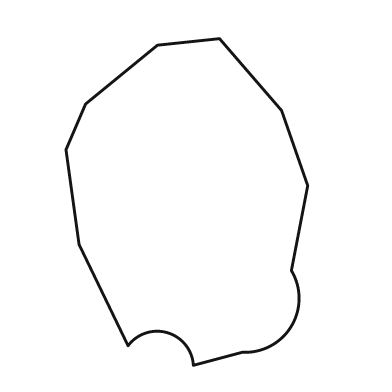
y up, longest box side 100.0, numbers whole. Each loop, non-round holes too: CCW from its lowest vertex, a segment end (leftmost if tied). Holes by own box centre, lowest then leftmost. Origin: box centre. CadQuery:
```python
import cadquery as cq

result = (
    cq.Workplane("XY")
    .moveTo(2.0, -50.0)
    .lineTo(17.0, -46.0)
    .threePointArc((32.0, -38.0), (32.0, -21.0))
    .lineTo(37.0, 5.0)
    .lineTo(29.0, 28.0)
    .lineTo(10.0, 50.0)
    .lineTo(-9.0, 48.0)
    .lineTo(-31.0, 30.0)
    .lineTo(-37.0, 16.0)
    .lineTo(-33.0, -13.0)
    .lineTo(-18.0, -44.0)
    .threePointArc((-6.0, -40.0), (2.0, -50.0))
    .close()
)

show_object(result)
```